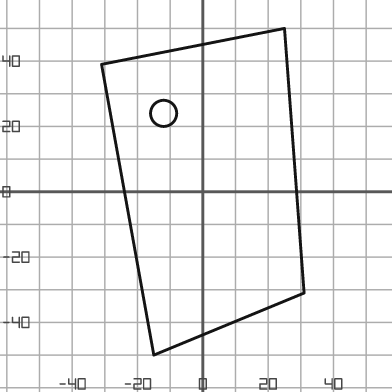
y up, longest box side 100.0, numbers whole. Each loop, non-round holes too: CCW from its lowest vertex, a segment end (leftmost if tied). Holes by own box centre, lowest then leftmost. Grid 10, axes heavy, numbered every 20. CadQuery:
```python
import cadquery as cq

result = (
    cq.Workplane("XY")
    .moveTo(-15.0, -50.0)
    .lineTo(31.0, -31.0)
    .lineTo(25.0, 50.0)
    .lineTo(-31.0, 39.0)
    .close()
    .moveTo(-12.0, 24.0)
    .circle(4.0)
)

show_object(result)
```